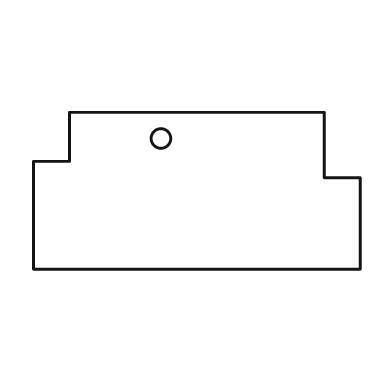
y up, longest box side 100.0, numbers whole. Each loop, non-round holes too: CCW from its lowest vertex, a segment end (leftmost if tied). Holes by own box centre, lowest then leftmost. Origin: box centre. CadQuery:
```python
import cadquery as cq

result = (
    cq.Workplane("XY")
    .moveTo(-50.0, -24.0)
    .lineTo(50.0, -24.0)
    .lineTo(50.0, 4.0)
    .lineTo(39.0, 4.0)
    .lineTo(39.0, 24.0)
    .lineTo(-39.0, 24.0)
    .lineTo(-39.0, 9.0)
    .lineTo(-50.0, 9.0)
    .close()
    .moveTo(-11.0, 16.0)
    .circle(3.0)
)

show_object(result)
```